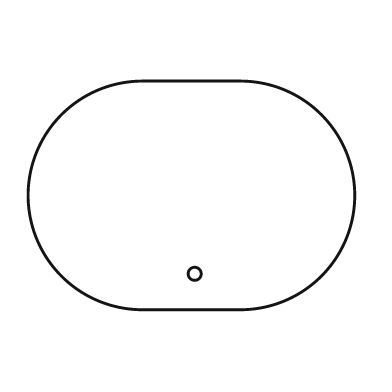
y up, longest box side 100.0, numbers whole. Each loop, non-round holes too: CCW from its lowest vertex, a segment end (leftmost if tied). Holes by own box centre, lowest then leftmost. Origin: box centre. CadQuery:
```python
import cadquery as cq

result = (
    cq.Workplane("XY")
    .moveTo(-15.0, -35.0)
    .lineTo(15.0, -35.0)
    .threePointArc((50.0, 0.0), (15.0, 35.0))
    .lineTo(-15.0, 35.0)
    .threePointArc((-50.0, 0.0), (-15.0, -35.0))
    .close()
    .moveTo(1.0, -24.0)
    .circle(2.0)
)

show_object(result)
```